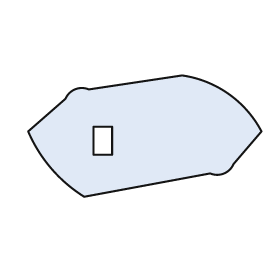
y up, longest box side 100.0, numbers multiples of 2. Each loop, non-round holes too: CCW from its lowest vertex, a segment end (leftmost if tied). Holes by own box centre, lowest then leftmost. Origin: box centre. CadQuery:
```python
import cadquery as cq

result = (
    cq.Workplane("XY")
    .moveTo(-26.0, -26.0)
    .lineTo(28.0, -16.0)
    .threePointArc((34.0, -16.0), (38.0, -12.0))
    .lineTo(50.0, 2.0)
    .threePointArc((36.0, 18.0), (16.0, 26.0))
    .lineTo(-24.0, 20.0)
    .threePointArc((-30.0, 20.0), (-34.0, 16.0))
    .lineTo(-50.0, 2.0)
    .threePointArc((-40.0, -14.0), (-26.0, -26.0))
    .close()
    .moveTo(-22.0, -8.0)
    .lineTo(-14.0, -8.0)
    .lineTo(-14.0, 4.0)
    .lineTo(-22.0, 4.0)
    .close()
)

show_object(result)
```